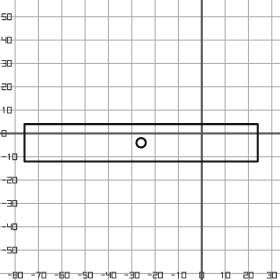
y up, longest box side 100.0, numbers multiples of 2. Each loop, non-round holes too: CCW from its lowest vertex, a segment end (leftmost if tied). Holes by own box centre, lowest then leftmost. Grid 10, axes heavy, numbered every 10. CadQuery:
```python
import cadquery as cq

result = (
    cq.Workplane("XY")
    .moveTo(-76.0, -12.0)
    .lineTo(24.0, -12.0)
    .lineTo(24.0, 4.0)
    .lineTo(-76.0, 4.0)
    .close()
    .moveTo(-26.0, -4.0)
    .circle(2.0)
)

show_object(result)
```